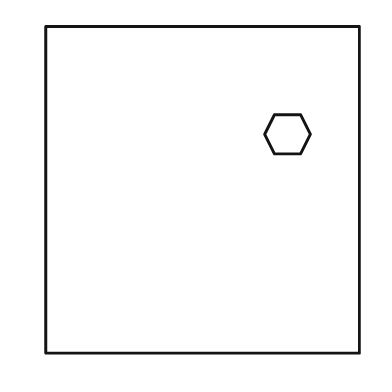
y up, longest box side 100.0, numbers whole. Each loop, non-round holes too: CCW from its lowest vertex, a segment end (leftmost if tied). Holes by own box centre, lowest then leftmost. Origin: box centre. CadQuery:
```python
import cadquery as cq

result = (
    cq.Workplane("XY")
    .moveTo(-48.0, -50.0)
    .lineTo(48.0, -50.0)
    .lineTo(48.0, 50.0)
    .lineTo(-48.0, 50.0)
    .close()
    .moveTo(22.0, 11.0)
    .lineTo(30.0, 11.0)
    .lineTo(33.0, 17.0)
    .lineTo(30.0, 23.0)
    .lineTo(22.0, 23.0)
    .lineTo(19.0, 17.0)
    .close()
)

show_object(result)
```